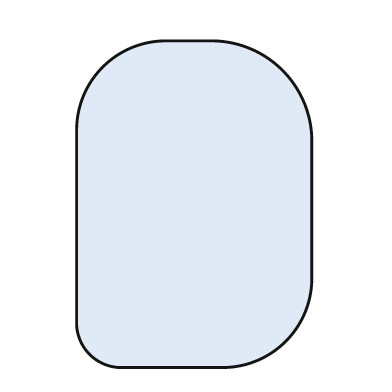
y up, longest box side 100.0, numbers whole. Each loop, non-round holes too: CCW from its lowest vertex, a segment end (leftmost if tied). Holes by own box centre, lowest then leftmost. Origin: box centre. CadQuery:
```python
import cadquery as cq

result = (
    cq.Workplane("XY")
    .moveTo(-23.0, -50.0)
    .lineTo(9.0, -50.0)
    .threePointArc((28.0, -42.0), (36.0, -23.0))
    .lineTo(36.0, 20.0)
    .threePointArc((27.0, 41.0), (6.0, 50.0))
    .lineTo(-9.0, 50.0)
    .threePointArc((-28.0, 42.0), (-36.0, 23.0))
    .lineTo(-36.0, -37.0)
    .threePointArc((-32.0, -46.0), (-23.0, -50.0))
    .close()
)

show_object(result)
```